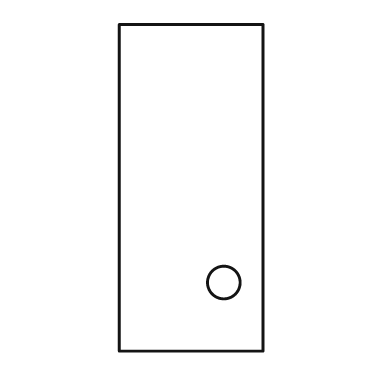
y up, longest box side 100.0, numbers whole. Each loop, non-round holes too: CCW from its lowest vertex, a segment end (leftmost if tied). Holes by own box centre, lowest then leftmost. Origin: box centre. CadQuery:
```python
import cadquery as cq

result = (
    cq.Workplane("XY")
    .moveTo(-22.0, -50.0)
    .lineTo(22.0, -50.0)
    .lineTo(22.0, 50.0)
    .lineTo(-22.0, 50.0)
    .close()
    .moveTo(10.0, -29.0)
    .circle(5.0)
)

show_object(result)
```